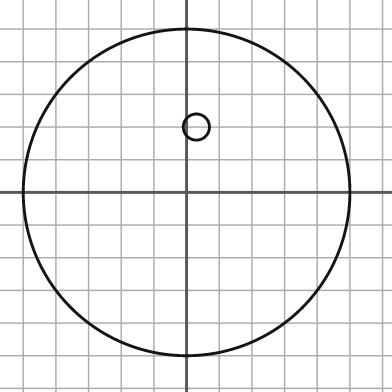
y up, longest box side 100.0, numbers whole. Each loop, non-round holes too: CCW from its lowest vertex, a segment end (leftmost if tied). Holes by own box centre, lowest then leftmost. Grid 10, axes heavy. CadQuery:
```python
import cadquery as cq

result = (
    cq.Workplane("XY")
    .moveTo(0.0, 0.0)
    .circle(50.0)
    .moveTo(3.0, 20.0)
    .circle(4.0)
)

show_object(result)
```